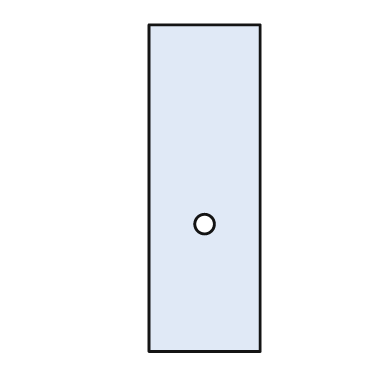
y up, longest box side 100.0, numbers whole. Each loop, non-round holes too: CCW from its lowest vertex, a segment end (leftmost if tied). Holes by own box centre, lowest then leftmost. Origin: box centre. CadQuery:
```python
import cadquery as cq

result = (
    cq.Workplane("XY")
    .moveTo(-17.0, -50.0)
    .lineTo(17.0, -50.0)
    .lineTo(17.0, 50.0)
    .lineTo(-17.0, 50.0)
    .close()
    .moveTo(0.0, -11.0)
    .circle(3.0)
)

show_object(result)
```